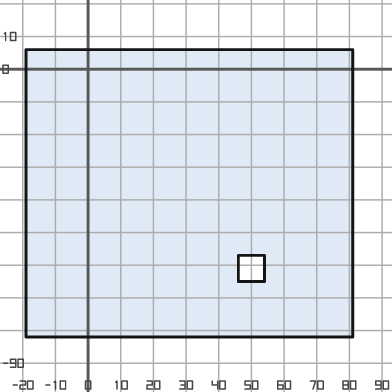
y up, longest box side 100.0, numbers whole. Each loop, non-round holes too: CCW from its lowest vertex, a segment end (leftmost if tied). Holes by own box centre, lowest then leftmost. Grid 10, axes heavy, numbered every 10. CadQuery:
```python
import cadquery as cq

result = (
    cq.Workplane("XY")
    .moveTo(-19.0, -82.0)
    .lineTo(81.0, -82.0)
    .lineTo(81.0, 6.0)
    .lineTo(-19.0, 6.0)
    .close()
    .moveTo(46.0, -65.0)
    .lineTo(54.0, -65.0)
    .lineTo(54.0, -57.0)
    .lineTo(46.0, -57.0)
    .close()
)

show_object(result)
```